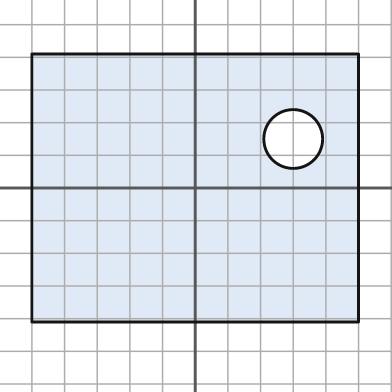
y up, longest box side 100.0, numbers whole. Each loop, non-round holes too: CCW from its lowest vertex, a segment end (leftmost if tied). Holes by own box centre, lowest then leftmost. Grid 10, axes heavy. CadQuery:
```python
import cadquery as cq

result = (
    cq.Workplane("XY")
    .moveTo(-50.0, -41.0)
    .lineTo(50.0, -41.0)
    .lineTo(50.0, 41.0)
    .lineTo(-50.0, 41.0)
    .close()
    .moveTo(30.0, 15.0)
    .circle(9.0)
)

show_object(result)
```